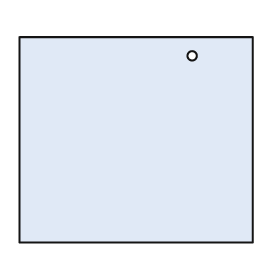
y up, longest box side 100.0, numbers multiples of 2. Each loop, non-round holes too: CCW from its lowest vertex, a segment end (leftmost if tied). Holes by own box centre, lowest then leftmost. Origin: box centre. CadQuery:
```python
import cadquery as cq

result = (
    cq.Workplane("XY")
    .moveTo(-50.0, -44.0)
    .lineTo(50.0, -44.0)
    .lineTo(50.0, 44.0)
    .lineTo(-50.0, 44.0)
    .close()
    .moveTo(24.0, 36.0)
    .circle(2.0)
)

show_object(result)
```